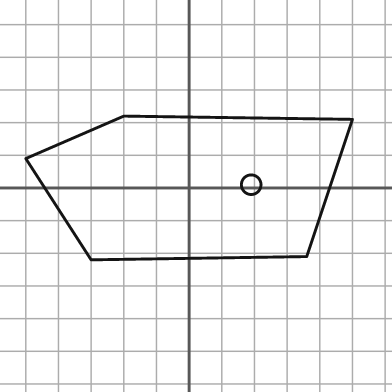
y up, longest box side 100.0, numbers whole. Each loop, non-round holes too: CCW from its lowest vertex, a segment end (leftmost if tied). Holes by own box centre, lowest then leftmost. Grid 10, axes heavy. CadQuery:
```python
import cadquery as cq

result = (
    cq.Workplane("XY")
    .moveTo(-30.0, -22.0)
    .lineTo(36.0, -21.0)
    .lineTo(50.0, 21.0)
    .lineTo(-20.0, 22.0)
    .lineTo(-50.0, 9.0)
    .close()
    .moveTo(19.0, 1.0)
    .circle(3.0)
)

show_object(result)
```